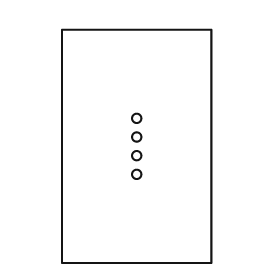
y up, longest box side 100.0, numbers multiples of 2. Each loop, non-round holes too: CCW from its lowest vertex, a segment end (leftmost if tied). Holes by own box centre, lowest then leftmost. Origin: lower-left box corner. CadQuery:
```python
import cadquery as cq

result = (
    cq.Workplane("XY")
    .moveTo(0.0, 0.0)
    .lineTo(64.0, 0.0)
    .lineTo(64.0, 100.0)
    .lineTo(0.0, 100.0)
    .close()
    .moveTo(32.0, 38.0)
    .circle(2.0)
    .moveTo(32.0, 46.0)
    .circle(2.0)
    .moveTo(32.0, 54.0)
    .circle(2.0)
    .moveTo(32.0, 62.0)
    .circle(2.0)
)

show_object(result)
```